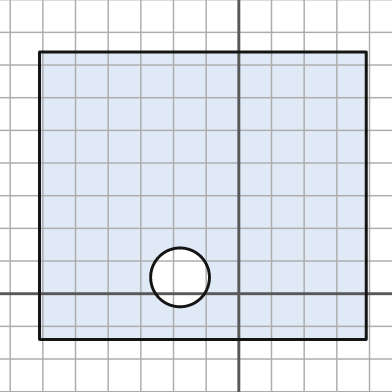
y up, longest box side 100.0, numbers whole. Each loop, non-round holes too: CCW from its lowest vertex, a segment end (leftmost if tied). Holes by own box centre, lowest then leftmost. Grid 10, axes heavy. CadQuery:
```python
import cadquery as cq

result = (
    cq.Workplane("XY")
    .moveTo(-61.0, -14.0)
    .lineTo(39.0, -14.0)
    .lineTo(39.0, 74.0)
    .lineTo(-61.0, 74.0)
    .close()
    .moveTo(-18.0, 5.0)
    .circle(9.0)
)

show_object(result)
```